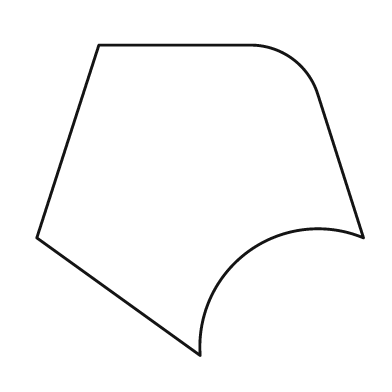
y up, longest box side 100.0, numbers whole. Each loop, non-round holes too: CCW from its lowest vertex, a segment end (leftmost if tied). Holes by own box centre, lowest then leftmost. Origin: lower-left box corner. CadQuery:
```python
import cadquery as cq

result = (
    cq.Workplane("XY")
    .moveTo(50.0, 0.0)
    .threePointArc((65.0, 32.0), (100.0, 36.0))
    .lineTo(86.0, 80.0)
    .threePointArc((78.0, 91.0), (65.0, 95.0))
    .lineTo(19.0, 95.0)
    .lineTo(0.0, 36.0)
    .close()
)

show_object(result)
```